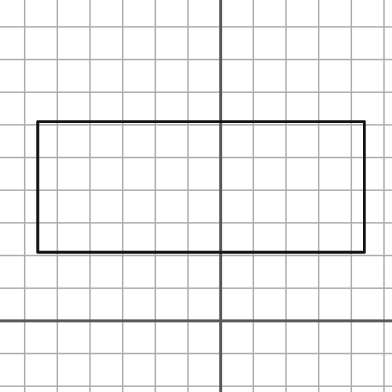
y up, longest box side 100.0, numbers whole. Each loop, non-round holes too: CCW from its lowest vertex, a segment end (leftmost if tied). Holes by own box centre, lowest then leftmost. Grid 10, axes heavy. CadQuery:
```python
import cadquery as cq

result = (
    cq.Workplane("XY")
    .moveTo(-56.0, 21.0)
    .lineTo(44.0, 21.0)
    .lineTo(44.0, 61.0)
    .lineTo(-56.0, 61.0)
    .close()
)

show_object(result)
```